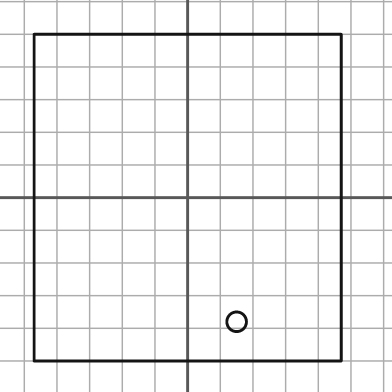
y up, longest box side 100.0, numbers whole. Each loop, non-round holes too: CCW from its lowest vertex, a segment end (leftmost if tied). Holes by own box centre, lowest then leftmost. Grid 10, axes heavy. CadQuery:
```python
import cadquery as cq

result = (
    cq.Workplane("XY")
    .moveTo(-47.0, -50.0)
    .lineTo(47.0, -50.0)
    .lineTo(47.0, 50.0)
    .lineTo(-47.0, 50.0)
    .close()
    .moveTo(15.0, -38.0)
    .circle(3.0)
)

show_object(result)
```